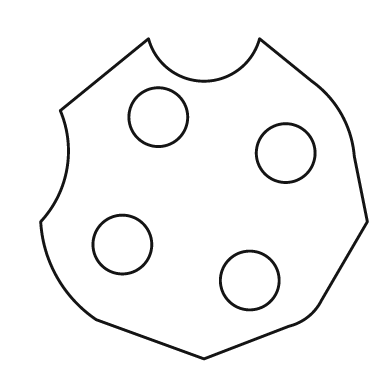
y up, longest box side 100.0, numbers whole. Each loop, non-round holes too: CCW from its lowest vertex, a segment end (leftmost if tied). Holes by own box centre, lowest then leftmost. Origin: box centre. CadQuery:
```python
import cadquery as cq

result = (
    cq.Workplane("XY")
    .moveTo(0.0, -49.0)
    .lineTo(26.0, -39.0)
    .threePointArc((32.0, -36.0), (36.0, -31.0))
    .lineTo(50.0, -7.0)
    .lineTo(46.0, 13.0)
    .threePointArc((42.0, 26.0), (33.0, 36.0))
    .lineTo(17.0, 49.0)
    .threePointArc((0.0, 36.0), (-17.0, 49.0))
    .lineTo(-44.0, 27.0)
    .threePointArc((-42.0, 9.0), (-50.0, -7.0))
    .threePointArc((-45.0, -24.0), (-33.0, -37.0))
    .close()
    .moveTo(14.0, -25.0)
    .circle(9.0)
    .moveTo(-25.0, -14.0)
    .circle(9.0)
    .moveTo(25.0, 14.0)
    .circle(9.0)
    .moveTo(-14.0, 25.0)
    .circle(9.0)
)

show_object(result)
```